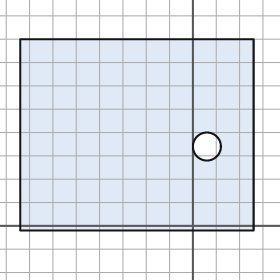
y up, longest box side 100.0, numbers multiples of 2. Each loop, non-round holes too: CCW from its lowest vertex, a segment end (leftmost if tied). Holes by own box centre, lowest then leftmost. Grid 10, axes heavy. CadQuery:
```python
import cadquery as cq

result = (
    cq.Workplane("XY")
    .moveTo(-74.0, -2.0)
    .lineTo(26.0, -2.0)
    .lineTo(26.0, 80.0)
    .lineTo(-74.0, 80.0)
    .close()
    .moveTo(6.0, 34.0)
    .circle(6.0)
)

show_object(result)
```